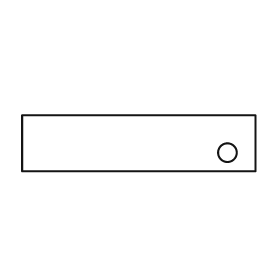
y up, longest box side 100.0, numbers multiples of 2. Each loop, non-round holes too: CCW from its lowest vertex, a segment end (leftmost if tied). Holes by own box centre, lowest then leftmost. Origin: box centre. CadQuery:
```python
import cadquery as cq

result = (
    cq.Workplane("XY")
    .moveTo(-50.0, -12.0)
    .lineTo(50.0, -12.0)
    .lineTo(50.0, 12.0)
    .lineTo(-50.0, 12.0)
    .close()
    .moveTo(38.0, -4.0)
    .circle(4.0)
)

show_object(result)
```